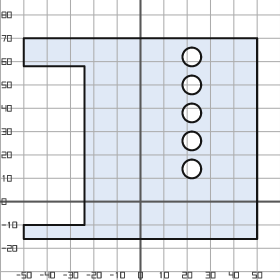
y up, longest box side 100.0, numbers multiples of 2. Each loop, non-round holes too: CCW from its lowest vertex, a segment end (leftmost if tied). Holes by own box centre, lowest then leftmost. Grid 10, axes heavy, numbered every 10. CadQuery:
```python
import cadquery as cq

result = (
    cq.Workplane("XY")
    .moveTo(-50.0, -16.0)
    .lineTo(50.0, -16.0)
    .lineTo(50.0, 70.0)
    .lineTo(-50.0, 70.0)
    .lineTo(-50.0, 58.0)
    .lineTo(-24.0, 58.0)
    .lineTo(-24.0, -10.0)
    .lineTo(-50.0, -10.0)
    .close()
    .moveTo(22.0, 14.0)
    .circle(4.0)
    .moveTo(22.0, 26.0)
    .circle(4.0)
    .moveTo(22.0, 38.0)
    .circle(4.0)
    .moveTo(22.0, 50.0)
    .circle(4.0)
    .moveTo(22.0, 62.0)
    .circle(4.0)
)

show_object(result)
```